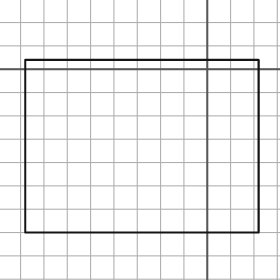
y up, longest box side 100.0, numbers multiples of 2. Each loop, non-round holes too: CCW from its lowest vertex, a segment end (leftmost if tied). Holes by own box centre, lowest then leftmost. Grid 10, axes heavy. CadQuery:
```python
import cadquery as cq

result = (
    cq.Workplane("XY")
    .moveTo(-78.0, -70.0)
    .lineTo(22.0, -70.0)
    .lineTo(22.0, 4.0)
    .lineTo(-78.0, 4.0)
    .close()
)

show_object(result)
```